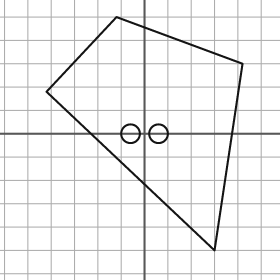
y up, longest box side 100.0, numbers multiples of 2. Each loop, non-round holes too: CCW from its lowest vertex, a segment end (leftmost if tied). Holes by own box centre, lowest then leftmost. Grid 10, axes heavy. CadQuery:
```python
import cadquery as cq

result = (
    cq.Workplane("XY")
    .moveTo(30.0, -50.0)
    .lineTo(42.0, 30.0)
    .lineTo(-12.0, 50.0)
    .lineTo(-42.0, 18.0)
    .close()
    .moveTo(-6.0, 0.0)
    .circle(4.0)
    .moveTo(6.0, 0.0)
    .circle(4.0)
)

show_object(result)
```